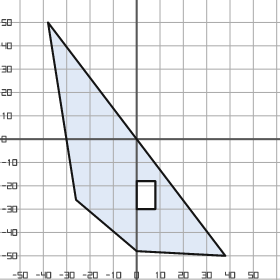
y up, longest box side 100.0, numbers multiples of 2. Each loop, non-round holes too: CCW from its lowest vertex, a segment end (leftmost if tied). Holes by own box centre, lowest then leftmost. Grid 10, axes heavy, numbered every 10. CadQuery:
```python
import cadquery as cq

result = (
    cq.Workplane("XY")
    .moveTo(38.0, -50.0)
    .lineTo(-38.0, 50.0)
    .lineTo(-26.0, -26.0)
    .lineTo(0.0, -48.0)
    .close()
    .moveTo(0.0, -30.0)
    .lineTo(8.0, -30.0)
    .lineTo(8.0, -18.0)
    .lineTo(0.0, -18.0)
    .close()
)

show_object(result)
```